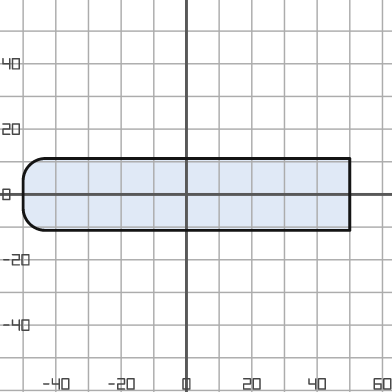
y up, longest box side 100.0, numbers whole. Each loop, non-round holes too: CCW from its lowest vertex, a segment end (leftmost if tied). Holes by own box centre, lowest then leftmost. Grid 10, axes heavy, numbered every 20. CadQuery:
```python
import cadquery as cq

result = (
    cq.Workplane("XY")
    .moveTo(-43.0, -11.0)
    .lineTo(50.0, -11.0)
    .lineTo(50.0, 11.0)
    .lineTo(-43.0, 11.0)
    .threePointArc((-48.0, 9.0), (-50.0, 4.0))
    .lineTo(-50.0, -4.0)
    .threePointArc((-48.0, -9.0), (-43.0, -11.0))
    .close()
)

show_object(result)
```